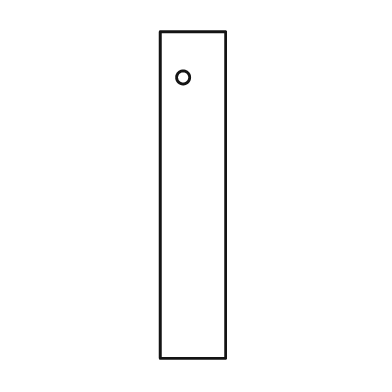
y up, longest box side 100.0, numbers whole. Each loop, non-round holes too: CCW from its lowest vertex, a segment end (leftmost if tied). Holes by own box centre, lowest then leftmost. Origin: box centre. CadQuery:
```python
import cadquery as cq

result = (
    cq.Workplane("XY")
    .moveTo(-10.0, -50.0)
    .lineTo(10.0, -50.0)
    .lineTo(10.0, 50.0)
    .lineTo(-10.0, 50.0)
    .close()
    .moveTo(-3.0, 36.0)
    .circle(2.0)
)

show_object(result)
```